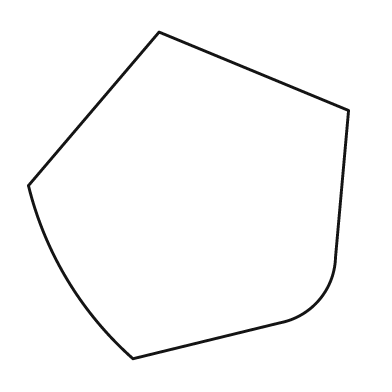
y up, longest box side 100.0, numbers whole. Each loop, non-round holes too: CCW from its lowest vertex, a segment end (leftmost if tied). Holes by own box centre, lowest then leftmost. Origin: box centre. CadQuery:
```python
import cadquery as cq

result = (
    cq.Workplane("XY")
    .moveTo(-17.0, -50.0)
    .lineTo(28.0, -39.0)
    .threePointArc((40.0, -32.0), (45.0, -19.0))
    .lineTo(49.0, 26.0)
    .lineTo(-9.0, 50.0)
    .lineTo(-49.0, 3.0)
    .threePointArc((-37.0, -26.0), (-17.0, -50.0))
    .close()
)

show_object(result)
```